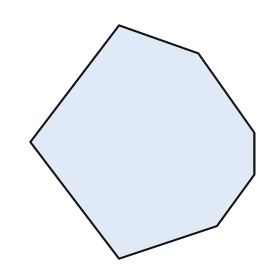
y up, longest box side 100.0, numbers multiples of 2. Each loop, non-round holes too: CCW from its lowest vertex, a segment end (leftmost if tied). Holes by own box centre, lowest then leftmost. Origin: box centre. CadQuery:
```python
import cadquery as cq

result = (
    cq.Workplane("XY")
    .moveTo(-10.0, -50.0)
    .lineTo(32.0, -36.0)
    .lineTo(48.0, -14.0)
    .lineTo(48.0, 4.0)
    .lineTo(24.0, 38.0)
    .lineTo(-10.0, 50.0)
    .lineTo(-48.0, 0.0)
    .close()
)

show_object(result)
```